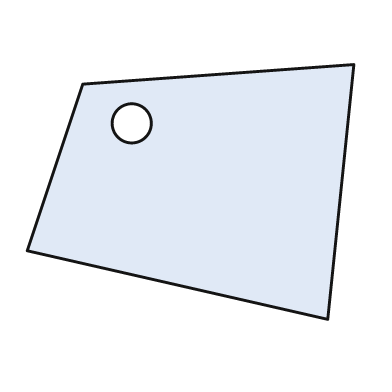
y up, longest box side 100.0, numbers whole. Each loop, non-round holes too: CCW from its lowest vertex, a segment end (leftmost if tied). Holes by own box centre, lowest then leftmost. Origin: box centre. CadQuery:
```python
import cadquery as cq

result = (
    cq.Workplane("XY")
    .moveTo(42.0, -39.0)
    .lineTo(50.0, 39.0)
    .lineTo(-33.0, 33.0)
    .lineTo(-50.0, -18.0)
    .close()
    .moveTo(-18.0, 21.0)
    .circle(6.0)
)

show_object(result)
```